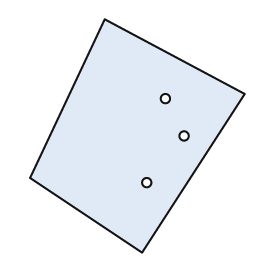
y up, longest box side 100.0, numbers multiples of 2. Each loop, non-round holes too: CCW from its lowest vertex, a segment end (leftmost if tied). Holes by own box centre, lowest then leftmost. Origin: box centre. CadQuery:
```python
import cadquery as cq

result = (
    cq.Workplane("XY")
    .moveTo(2.0, -50.0)
    .lineTo(46.0, 18.0)
    .lineTo(-14.0, 50.0)
    .lineTo(-46.0, -18.0)
    .close()
    .moveTo(4.0, -20.0)
    .circle(2.0)
    .moveTo(20.0, 0.0)
    .circle(2.0)
    .moveTo(12.0, 16.0)
    .circle(2.0)
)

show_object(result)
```